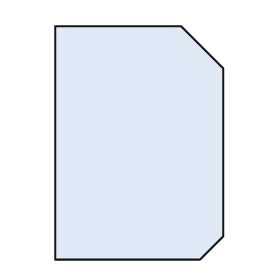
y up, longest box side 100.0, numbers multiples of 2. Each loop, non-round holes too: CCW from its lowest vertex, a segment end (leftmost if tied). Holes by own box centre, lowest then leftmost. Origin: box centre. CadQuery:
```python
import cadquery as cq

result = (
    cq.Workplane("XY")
    .moveTo(-36.0, -50.0)
    .lineTo(26.0, -50.0)
    .lineTo(36.0, -40.0)
    .lineTo(36.0, 32.0)
    .lineTo(18.0, 50.0)
    .lineTo(-36.0, 50.0)
    .close()
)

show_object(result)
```